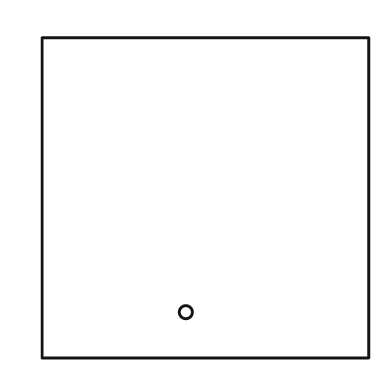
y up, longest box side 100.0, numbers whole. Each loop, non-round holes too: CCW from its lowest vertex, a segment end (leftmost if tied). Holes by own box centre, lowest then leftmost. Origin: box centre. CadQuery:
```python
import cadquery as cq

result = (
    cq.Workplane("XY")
    .moveTo(-50.0, -49.0)
    .lineTo(50.0, -49.0)
    .lineTo(50.0, 49.0)
    .lineTo(-50.0, 49.0)
    .close()
    .moveTo(-6.0, -35.0)
    .circle(2.0)
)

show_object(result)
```